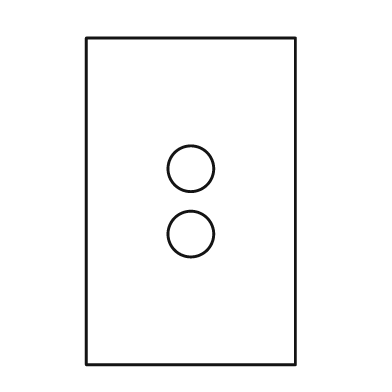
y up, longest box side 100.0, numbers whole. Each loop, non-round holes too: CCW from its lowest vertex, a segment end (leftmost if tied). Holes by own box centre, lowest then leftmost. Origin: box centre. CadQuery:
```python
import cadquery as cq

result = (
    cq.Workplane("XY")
    .moveTo(-32.0, -50.0)
    .lineTo(32.0, -50.0)
    .lineTo(32.0, 50.0)
    .lineTo(-32.0, 50.0)
    .close()
    .moveTo(0.0, -10.0)
    .circle(7.0)
    .moveTo(0.0, 10.0)
    .circle(7.0)
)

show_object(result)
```